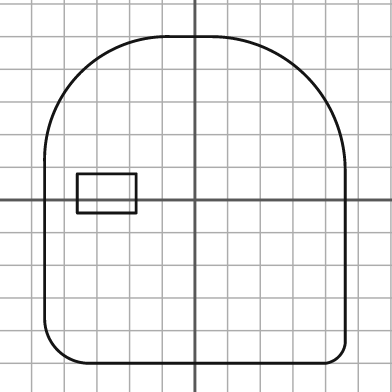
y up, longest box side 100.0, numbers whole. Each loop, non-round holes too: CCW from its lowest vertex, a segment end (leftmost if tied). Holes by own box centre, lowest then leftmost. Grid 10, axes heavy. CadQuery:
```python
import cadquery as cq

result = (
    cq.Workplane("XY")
    .moveTo(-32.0, -50.0)
    .lineTo(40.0, -50.0)
    .threePointArc((44.0, -48.0), (46.0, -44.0))
    .lineTo(46.0, 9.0)
    .threePointArc((34.0, 38.0), (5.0, 50.0))
    .lineTo(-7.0, 50.0)
    .threePointArc((-35.0, 39.0), (-46.0, 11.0))
    .lineTo(-46.0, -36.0)
    .threePointArc((-42.0, -46.0), (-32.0, -50.0))
    .close()
    .moveTo(-36.0, -4.0)
    .lineTo(-18.0, -4.0)
    .lineTo(-18.0, 8.0)
    .lineTo(-36.0, 8.0)
    .close()
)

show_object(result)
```